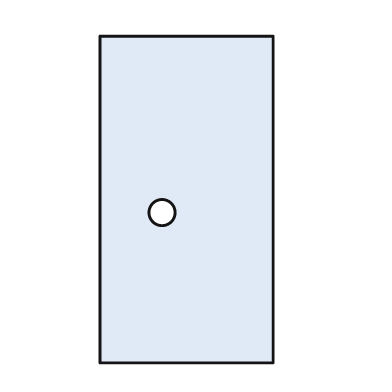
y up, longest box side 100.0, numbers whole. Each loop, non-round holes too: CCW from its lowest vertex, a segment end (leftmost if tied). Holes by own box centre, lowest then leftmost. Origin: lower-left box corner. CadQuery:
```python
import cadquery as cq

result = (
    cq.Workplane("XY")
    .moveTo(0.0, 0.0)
    .lineTo(53.0, 0.0)
    .lineTo(53.0, 100.0)
    .lineTo(0.0, 100.0)
    .close()
    .moveTo(19.0, 46.0)
    .circle(4.0)
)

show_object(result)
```